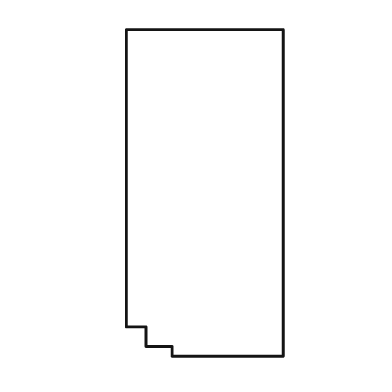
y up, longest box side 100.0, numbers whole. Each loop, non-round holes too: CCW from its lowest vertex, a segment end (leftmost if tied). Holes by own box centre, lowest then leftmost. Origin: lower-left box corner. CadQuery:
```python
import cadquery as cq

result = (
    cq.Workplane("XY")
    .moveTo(14.0, 0.0)
    .lineTo(48.0, 0.0)
    .lineTo(48.0, 100.0)
    .lineTo(0.0, 100.0)
    .lineTo(0.0, 9.0)
    .lineTo(6.0, 9.0)
    .lineTo(6.0, 3.0)
    .lineTo(14.0, 3.0)
    .close()
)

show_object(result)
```